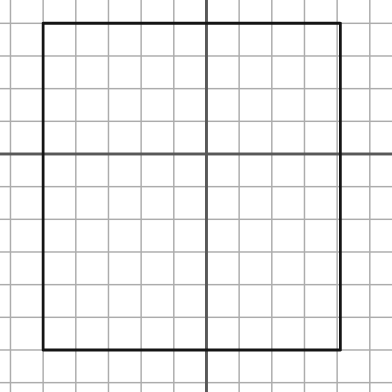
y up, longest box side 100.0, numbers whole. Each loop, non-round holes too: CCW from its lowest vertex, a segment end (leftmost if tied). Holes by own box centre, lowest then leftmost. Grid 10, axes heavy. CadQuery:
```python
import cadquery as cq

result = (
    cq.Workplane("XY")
    .moveTo(-50.0, -60.0)
    .lineTo(41.0, -60.0)
    .lineTo(41.0, 40.0)
    .lineTo(-50.0, 40.0)
    .close()
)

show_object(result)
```